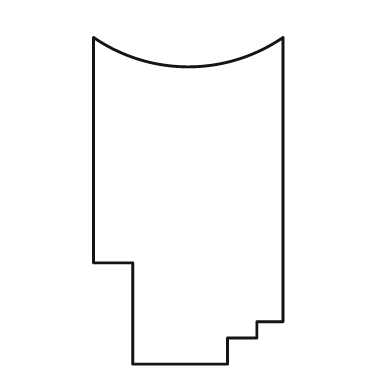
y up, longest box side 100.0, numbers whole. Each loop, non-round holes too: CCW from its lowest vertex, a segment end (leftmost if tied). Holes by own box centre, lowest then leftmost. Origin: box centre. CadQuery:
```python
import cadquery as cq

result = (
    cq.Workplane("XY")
    .moveTo(-17.0, -50.0)
    .lineTo(12.0, -50.0)
    .lineTo(12.0, -42.0)
    .lineTo(21.0, -42.0)
    .lineTo(21.0, -37.0)
    .lineTo(29.0, -37.0)
    .lineTo(29.0, 50.0)
    .threePointArc((0.0, 41.0), (-29.0, 50.0))
    .lineTo(-29.0, -19.0)
    .lineTo(-17.0, -19.0)
    .close()
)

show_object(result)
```